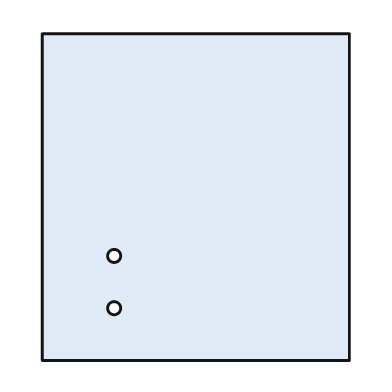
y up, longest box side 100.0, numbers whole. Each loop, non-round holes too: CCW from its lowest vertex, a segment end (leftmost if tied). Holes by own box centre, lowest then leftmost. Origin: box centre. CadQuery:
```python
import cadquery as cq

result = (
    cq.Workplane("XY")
    .moveTo(-47.0, -50.0)
    .lineTo(47.0, -50.0)
    .lineTo(47.0, 50.0)
    .lineTo(-47.0, 50.0)
    .close()
    .moveTo(-25.0, -34.0)
    .circle(2.0)
    .moveTo(-25.0, -18.0)
    .circle(2.0)
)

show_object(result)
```